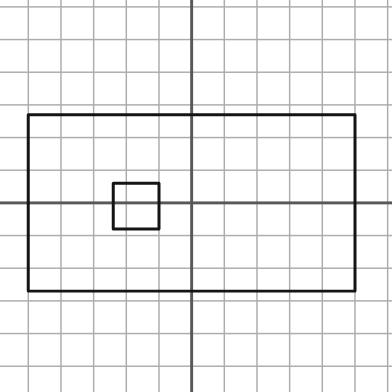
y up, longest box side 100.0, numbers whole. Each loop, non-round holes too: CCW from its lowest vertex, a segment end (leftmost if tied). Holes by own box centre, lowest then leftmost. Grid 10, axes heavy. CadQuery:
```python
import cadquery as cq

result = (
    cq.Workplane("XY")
    .moveTo(-50.0, -27.0)
    .lineTo(50.0, -27.0)
    .lineTo(50.0, 27.0)
    .lineTo(-50.0, 27.0)
    .close()
    .moveTo(-24.0, -8.0)
    .lineTo(-10.0, -8.0)
    .lineTo(-10.0, 6.0)
    .lineTo(-24.0, 6.0)
    .close()
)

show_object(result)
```